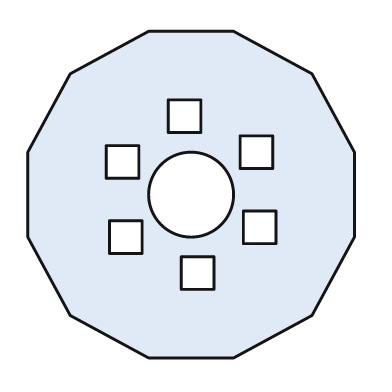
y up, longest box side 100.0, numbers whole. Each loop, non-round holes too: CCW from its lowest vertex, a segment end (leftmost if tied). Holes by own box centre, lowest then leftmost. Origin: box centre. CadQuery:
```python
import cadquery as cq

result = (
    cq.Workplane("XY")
    .moveTo(-13.0, -50.0)
    .lineTo(13.0, -50.0)
    .lineTo(37.0, -37.0)
    .lineTo(50.0, -13.0)
    .lineTo(50.0, 13.0)
    .lineTo(37.0, 37.0)
    .lineTo(13.0, 50.0)
    .lineTo(-13.0, 50.0)
    .lineTo(-37.0, 37.0)
    .lineTo(-50.0, 13.0)
    .lineTo(-50.0, -13.0)
    .lineTo(-37.0, -37.0)
    .close()
    .moveTo(-3.0, -29.0)
    .lineTo(7.0, -29.0)
    .lineTo(7.0, -19.0)
    .lineTo(-3.0, -19.0)
    .close()
    .moveTo(-25.0, -18.0)
    .lineTo(-15.0, -18.0)
    .lineTo(-15.0, -8.0)
    .lineTo(-25.0, -8.0)
    .close()
    .moveTo(16.0, -15.0)
    .lineTo(26.0, -15.0)
    .lineTo(26.0, -5.0)
    .lineTo(16.0, -5.0)
    .close()
    .moveTo(0.0, 0.0)
    .circle(13.0)
    .moveTo(-26.0, 5.0)
    .lineTo(-16.0, 5.0)
    .lineTo(-16.0, 15.0)
    .lineTo(-26.0, 15.0)
    .close()
    .moveTo(15.0, 8.0)
    .lineTo(25.0, 8.0)
    .lineTo(25.0, 18.0)
    .lineTo(15.0, 18.0)
    .close()
    .moveTo(-7.0, 19.0)
    .lineTo(3.0, 19.0)
    .lineTo(3.0, 29.0)
    .lineTo(-7.0, 29.0)
    .close()
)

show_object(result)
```